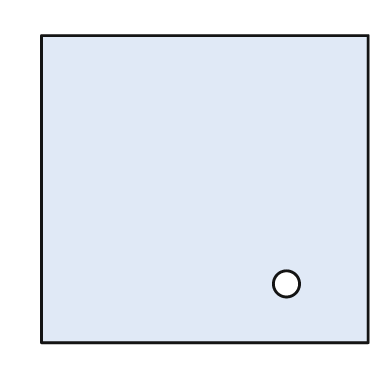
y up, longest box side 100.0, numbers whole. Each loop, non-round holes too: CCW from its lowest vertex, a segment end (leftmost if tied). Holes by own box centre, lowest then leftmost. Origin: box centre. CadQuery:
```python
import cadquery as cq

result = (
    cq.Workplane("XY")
    .moveTo(-50.0, -47.0)
    .lineTo(50.0, -47.0)
    .lineTo(50.0, 47.0)
    .lineTo(-50.0, 47.0)
    .close()
    .moveTo(25.0, -29.0)
    .circle(4.0)
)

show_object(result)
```